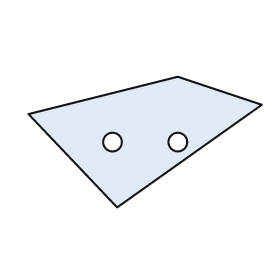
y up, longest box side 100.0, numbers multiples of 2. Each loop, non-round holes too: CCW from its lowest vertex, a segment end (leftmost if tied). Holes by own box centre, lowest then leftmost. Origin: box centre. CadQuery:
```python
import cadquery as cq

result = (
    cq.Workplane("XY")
    .moveTo(-12.0, -28.0)
    .lineTo(50.0, 16.0)
    .lineTo(14.0, 28.0)
    .lineTo(-50.0, 12.0)
    .close()
    .moveTo(-14.0, 0.0)
    .circle(4.0)
    .moveTo(14.0, 0.0)
    .circle(4.0)
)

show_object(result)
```